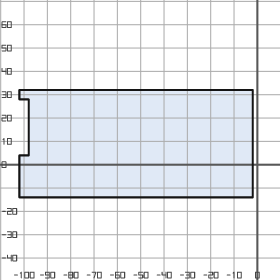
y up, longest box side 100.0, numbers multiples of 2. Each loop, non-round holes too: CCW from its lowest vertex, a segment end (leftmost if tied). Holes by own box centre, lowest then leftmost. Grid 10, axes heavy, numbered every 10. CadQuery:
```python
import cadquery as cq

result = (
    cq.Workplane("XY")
    .moveTo(-102.0, -14.0)
    .lineTo(-2.0, -14.0)
    .lineTo(-2.0, 32.0)
    .lineTo(-102.0, 32.0)
    .lineTo(-102.0, 28.0)
    .lineTo(-98.0, 28.0)
    .lineTo(-98.0, 4.0)
    .lineTo(-102.0, 4.0)
    .close()
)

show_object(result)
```